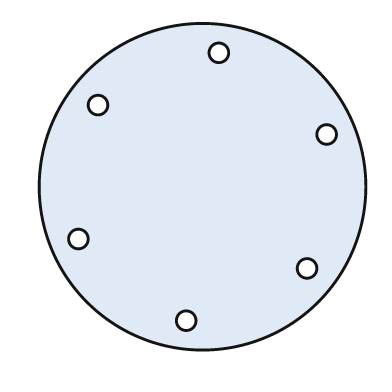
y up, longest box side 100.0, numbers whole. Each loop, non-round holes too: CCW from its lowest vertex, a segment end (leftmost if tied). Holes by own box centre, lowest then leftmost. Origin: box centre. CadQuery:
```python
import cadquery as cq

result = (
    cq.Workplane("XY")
    .moveTo(0.0, 0.0)
    .circle(50.0)
    .moveTo(-5.0, -41.0)
    .circle(3.0)
    .moveTo(32.0, -25.0)
    .circle(3.0)
    .moveTo(-38.0, -16.0)
    .circle(3.0)
    .moveTo(38.0, 16.0)
    .circle(3.0)
    .moveTo(-32.0, 25.0)
    .circle(3.0)
    .moveTo(5.0, 41.0)
    .circle(3.0)
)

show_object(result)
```